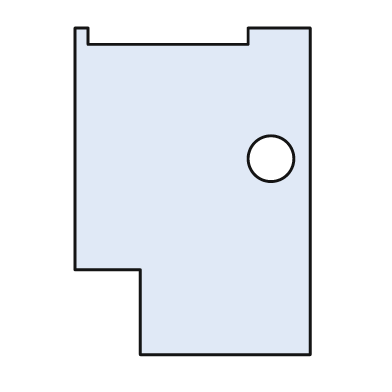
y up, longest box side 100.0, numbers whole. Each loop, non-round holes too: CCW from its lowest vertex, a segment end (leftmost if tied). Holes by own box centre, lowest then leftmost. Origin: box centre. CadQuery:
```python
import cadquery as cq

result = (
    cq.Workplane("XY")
    .moveTo(-16.0, -50.0)
    .lineTo(36.0, -50.0)
    .lineTo(36.0, 50.0)
    .lineTo(17.0, 50.0)
    .lineTo(17.0, 45.0)
    .lineTo(-32.0, 45.0)
    .lineTo(-32.0, 50.0)
    .lineTo(-36.0, 50.0)
    .lineTo(-36.0, -24.0)
    .lineTo(-16.0, -24.0)
    .close()
    .moveTo(24.0, 10.0)
    .circle(7.0)
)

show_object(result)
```